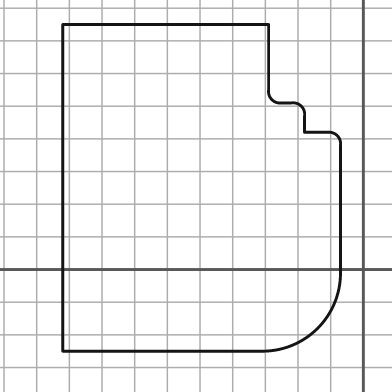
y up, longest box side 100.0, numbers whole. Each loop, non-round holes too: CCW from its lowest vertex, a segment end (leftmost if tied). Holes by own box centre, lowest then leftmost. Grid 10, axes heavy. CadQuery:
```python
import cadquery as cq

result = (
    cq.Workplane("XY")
    .moveTo(-92.0, -25.0)
    .lineTo(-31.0, -25.0)
    .threePointArc((-14.0, -18.0), (-7.0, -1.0))
    .lineTo(-7.0, 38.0)
    .threePointArc((-8.0, 41.0), (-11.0, 42.0))
    .lineTo(-18.0, 42.0)
    .lineTo(-18.0, 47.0)
    .threePointArc((-19.0, 50.0), (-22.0, 51.0))
    .lineTo(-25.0, 51.0)
    .threePointArc((-28.0, 52.0), (-29.0, 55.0))
    .lineTo(-29.0, 75.0)
    .lineTo(-92.0, 75.0)
    .close()
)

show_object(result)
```